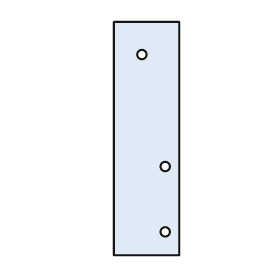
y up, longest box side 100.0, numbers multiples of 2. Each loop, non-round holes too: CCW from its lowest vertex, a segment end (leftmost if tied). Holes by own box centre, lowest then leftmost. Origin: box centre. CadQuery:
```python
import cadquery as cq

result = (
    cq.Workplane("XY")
    .moveTo(-14.0, -50.0)
    .lineTo(14.0, -50.0)
    .lineTo(14.0, 50.0)
    .lineTo(-14.0, 50.0)
    .close()
    .moveTo(8.0, -40.0)
    .circle(2.0)
    .moveTo(8.0, -12.0)
    .circle(2.0)
    .moveTo(-2.0, 36.0)
    .circle(2.0)
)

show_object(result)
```